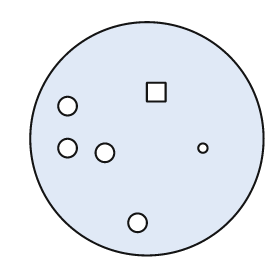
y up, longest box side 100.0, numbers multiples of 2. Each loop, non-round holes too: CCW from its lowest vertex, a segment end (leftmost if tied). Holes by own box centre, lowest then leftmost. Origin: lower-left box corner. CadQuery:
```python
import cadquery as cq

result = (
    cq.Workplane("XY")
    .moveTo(50.0, 50.0)
    .circle(50.0)
    .moveTo(46.0, 14.0)
    .circle(4.0)
    .moveTo(32.0, 44.0)
    .circle(4.0)
    .moveTo(16.0, 46.0)
    .circle(4.0)
    .moveTo(74.0, 46.0)
    .circle(2.0)
    .moveTo(16.0, 64.0)
    .circle(4.0)
    .moveTo(50.0, 66.0)
    .lineTo(58.0, 66.0)
    .lineTo(58.0, 74.0)
    .lineTo(50.0, 74.0)
    .close()
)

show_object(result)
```